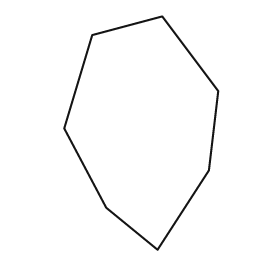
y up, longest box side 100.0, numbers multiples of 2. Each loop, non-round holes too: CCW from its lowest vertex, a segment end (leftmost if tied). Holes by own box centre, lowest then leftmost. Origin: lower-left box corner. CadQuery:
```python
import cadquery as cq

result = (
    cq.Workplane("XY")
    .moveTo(40.0, 0.0)
    .lineTo(62.0, 34.0)
    .lineTo(66.0, 68.0)
    .lineTo(42.0, 100.0)
    .lineTo(12.0, 92.0)
    .lineTo(0.0, 52.0)
    .lineTo(18.0, 18.0)
    .close()
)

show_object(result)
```